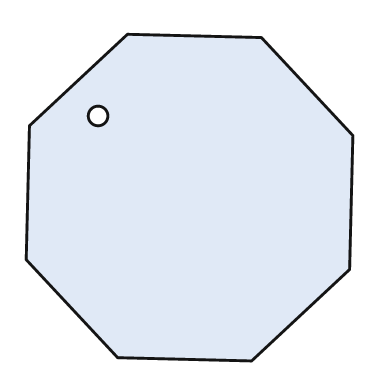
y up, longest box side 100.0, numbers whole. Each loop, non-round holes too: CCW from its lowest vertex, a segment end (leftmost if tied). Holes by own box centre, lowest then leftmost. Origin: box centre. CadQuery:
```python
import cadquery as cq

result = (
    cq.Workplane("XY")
    .moveTo(19.0, -50.0)
    .lineTo(49.0, -22.0)
    .lineTo(50.0, 19.0)
    .lineTo(22.0, 49.0)
    .lineTo(-19.0, 50.0)
    .lineTo(-49.0, 22.0)
    .lineTo(-50.0, -19.0)
    .lineTo(-22.0, -49.0)
    .close()
    .moveTo(-28.0, 25.0)
    .circle(3.0)
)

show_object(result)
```